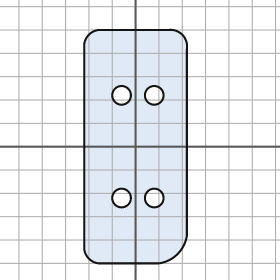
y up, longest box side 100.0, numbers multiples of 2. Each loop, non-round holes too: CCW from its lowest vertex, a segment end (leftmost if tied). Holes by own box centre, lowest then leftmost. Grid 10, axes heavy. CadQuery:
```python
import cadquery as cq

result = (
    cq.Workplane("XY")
    .moveTo(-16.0, -50.0)
    .lineTo(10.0, -50.0)
    .threePointArc((18.0, -46.0), (22.0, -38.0))
    .lineTo(22.0, 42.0)
    .threePointArc((20.0, 48.0), (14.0, 50.0))
    .lineTo(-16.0, 50.0)
    .threePointArc((-20.0, 48.0), (-22.0, 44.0))
    .lineTo(-22.0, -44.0)
    .threePointArc((-20.0, -48.0), (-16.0, -50.0))
    .close()
    .moveTo(-6.0, -22.0)
    .circle(4.0)
    .moveTo(8.0, -22.0)
    .circle(4.0)
    .moveTo(-6.0, 22.0)
    .circle(4.0)
    .moveTo(8.0, 22.0)
    .circle(4.0)
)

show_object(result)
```